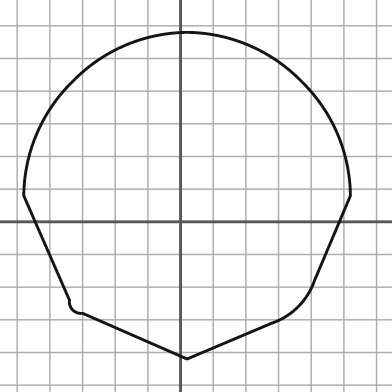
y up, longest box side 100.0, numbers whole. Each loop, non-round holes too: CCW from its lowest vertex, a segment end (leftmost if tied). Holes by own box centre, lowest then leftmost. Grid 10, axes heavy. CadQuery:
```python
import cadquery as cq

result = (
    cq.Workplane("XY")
    .moveTo(2.0, -42.0)
    .lineTo(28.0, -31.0)
    .threePointArc((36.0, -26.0), (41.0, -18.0))
    .lineTo(52.0, 8.0)
    .threePointArc((48.0, 27.0), (37.0, 43.0))
    .threePointArc((21.0, 54.0), (2.0, 58.0))
    .threePointArc((-17.0, 54.0), (-33.0, 43.0))
    .threePointArc((-44.0, 27.0), (-48.0, 8.0))
    .lineTo(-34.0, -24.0)
    .threePointArc((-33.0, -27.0), (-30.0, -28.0))
    .close()
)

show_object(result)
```